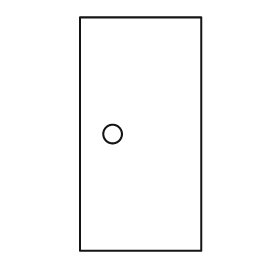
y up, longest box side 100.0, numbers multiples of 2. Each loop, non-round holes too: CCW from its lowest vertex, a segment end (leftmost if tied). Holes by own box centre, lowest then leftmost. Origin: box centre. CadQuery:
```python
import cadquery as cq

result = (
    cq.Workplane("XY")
    .moveTo(-26.0, -50.0)
    .lineTo(26.0, -50.0)
    .lineTo(26.0, 50.0)
    .lineTo(-26.0, 50.0)
    .close()
    .moveTo(-12.0, 0.0)
    .circle(4.0)
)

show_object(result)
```